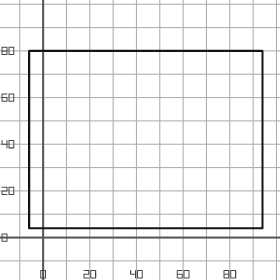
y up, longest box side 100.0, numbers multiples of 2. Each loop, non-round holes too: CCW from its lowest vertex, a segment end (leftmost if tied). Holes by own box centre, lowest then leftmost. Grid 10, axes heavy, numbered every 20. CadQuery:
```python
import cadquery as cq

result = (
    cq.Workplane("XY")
    .moveTo(-6.0, 4.0)
    .lineTo(94.0, 4.0)
    .lineTo(94.0, 80.0)
    .lineTo(-6.0, 80.0)
    .close()
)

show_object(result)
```